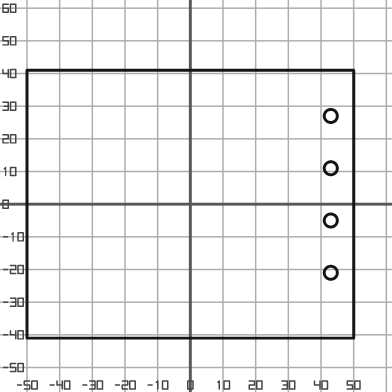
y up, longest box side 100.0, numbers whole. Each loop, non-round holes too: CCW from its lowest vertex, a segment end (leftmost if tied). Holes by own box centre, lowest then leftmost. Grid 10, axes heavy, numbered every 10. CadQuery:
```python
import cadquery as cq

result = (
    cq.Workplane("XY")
    .moveTo(-50.0, -41.0)
    .lineTo(50.0, -41.0)
    .lineTo(50.0, 41.0)
    .lineTo(-50.0, 41.0)
    .close()
    .moveTo(43.0, -21.0)
    .circle(2.0)
    .moveTo(43.0, -5.0)
    .circle(2.0)
    .moveTo(43.0, 11.0)
    .circle(2.0)
    .moveTo(43.0, 27.0)
    .circle(2.0)
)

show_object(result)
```